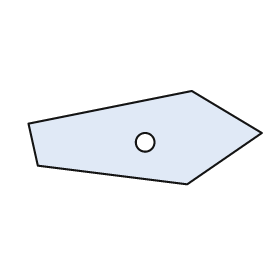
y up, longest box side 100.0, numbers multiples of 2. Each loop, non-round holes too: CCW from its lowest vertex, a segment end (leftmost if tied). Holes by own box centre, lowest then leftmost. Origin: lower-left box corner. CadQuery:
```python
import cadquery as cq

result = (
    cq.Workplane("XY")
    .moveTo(68.0, 0.0)
    .lineTo(100.0, 22.0)
    .lineTo(70.0, 40.0)
    .lineTo(0.0, 26.0)
    .lineTo(4.0, 8.0)
    .close()
    .moveTo(50.0, 18.0)
    .circle(4.0)
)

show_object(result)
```